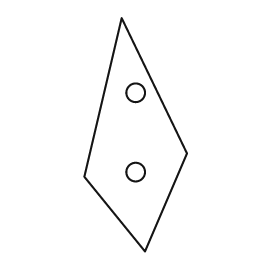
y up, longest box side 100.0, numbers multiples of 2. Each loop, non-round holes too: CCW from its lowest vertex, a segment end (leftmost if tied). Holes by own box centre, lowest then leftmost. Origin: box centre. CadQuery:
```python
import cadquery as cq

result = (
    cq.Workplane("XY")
    .moveTo(4.0, -50.0)
    .lineTo(22.0, -8.0)
    .lineTo(-6.0, 50.0)
    .lineTo(-22.0, -18.0)
    .close()
    .moveTo(0.0, -16.0)
    .circle(4.0)
    .moveTo(0.0, 18.0)
    .circle(4.0)
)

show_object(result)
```